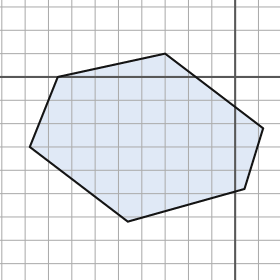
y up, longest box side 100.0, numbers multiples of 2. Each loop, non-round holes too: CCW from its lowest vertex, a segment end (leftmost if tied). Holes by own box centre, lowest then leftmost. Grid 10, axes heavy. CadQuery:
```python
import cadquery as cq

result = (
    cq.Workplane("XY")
    .moveTo(-46.0, -62.0)
    .lineTo(4.0, -48.0)
    .lineTo(12.0, -22.0)
    .lineTo(-30.0, 10.0)
    .lineTo(-76.0, 0.0)
    .lineTo(-88.0, -30.0)
    .close()
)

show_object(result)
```